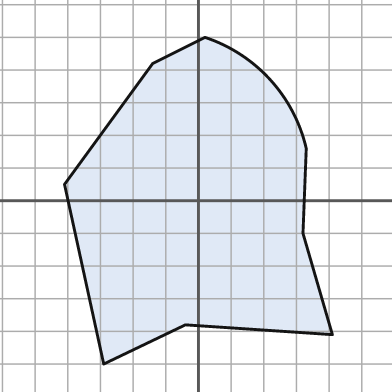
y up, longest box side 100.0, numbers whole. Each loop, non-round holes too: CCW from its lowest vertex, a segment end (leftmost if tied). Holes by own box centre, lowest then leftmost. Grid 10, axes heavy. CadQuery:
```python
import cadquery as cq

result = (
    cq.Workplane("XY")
    .moveTo(-29.0, -50.0)
    .lineTo(-4.0, -38.0)
    .lineTo(41.0, -41.0)
    .lineTo(32.0, -10.0)
    .lineTo(33.0, 16.0)
    .threePointArc((22.0, 37.0), (2.0, 50.0))
    .lineTo(-14.0, 42.0)
    .lineTo(-41.0, 5.0)
    .close()
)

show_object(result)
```